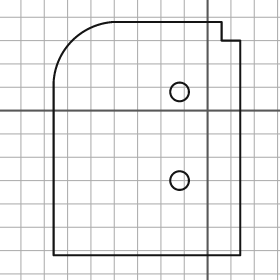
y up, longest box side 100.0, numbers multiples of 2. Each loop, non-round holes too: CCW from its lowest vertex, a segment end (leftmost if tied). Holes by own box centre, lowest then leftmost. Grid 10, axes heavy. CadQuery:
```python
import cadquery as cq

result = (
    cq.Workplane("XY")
    .moveTo(-66.0, -62.0)
    .lineTo(14.0, -62.0)
    .lineTo(14.0, 30.0)
    .lineTo(6.0, 30.0)
    .lineTo(6.0, 38.0)
    .lineTo(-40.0, 38.0)
    .threePointArc((-58.0, 30.0), (-66.0, 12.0))
    .close()
    .moveTo(-12.0, -30.0)
    .circle(4.0)
    .moveTo(-12.0, 8.0)
    .circle(4.0)
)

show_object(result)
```